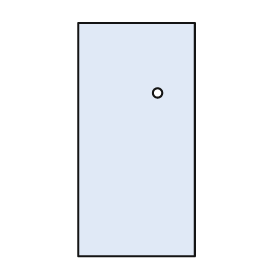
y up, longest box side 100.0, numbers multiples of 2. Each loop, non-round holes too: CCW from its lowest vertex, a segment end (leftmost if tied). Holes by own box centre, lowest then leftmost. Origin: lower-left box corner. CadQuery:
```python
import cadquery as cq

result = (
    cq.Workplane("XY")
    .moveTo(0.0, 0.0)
    .lineTo(50.0, 0.0)
    .lineTo(50.0, 100.0)
    .lineTo(0.0, 100.0)
    .close()
    .moveTo(34.0, 70.0)
    .circle(2.0)
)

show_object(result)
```